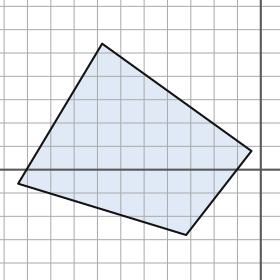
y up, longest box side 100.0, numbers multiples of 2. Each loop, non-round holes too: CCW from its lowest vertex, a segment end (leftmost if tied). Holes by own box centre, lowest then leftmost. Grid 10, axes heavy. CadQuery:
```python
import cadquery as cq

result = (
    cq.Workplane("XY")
    .moveTo(-32.0, -28.0)
    .lineTo(-4.0, 8.0)
    .lineTo(-68.0, 54.0)
    .lineTo(-104.0, -6.0)
    .close()
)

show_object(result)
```